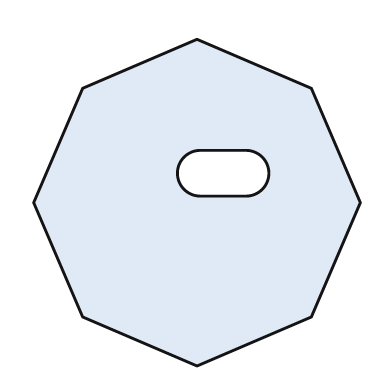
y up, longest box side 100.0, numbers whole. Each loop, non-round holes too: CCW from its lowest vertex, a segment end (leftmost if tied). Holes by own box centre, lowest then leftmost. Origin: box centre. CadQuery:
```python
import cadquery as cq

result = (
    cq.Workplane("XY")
    .moveTo(0.0, -50.0)
    .lineTo(35.0, -35.0)
    .lineTo(50.0, 0.0)
    .lineTo(35.0, 35.0)
    .lineTo(0.0, 50.0)
    .lineTo(-35.0, 35.0)
    .lineTo(-50.0, 0.0)
    .lineTo(-35.0, -35.0)
    .close()
    .moveTo(1.0, 2.0)
    .lineTo(15.0, 2.0)
    .threePointArc((22.0, 9.0), (15.0, 16.0))
    .lineTo(1.0, 16.0)
    .threePointArc((-6.0, 9.0), (1.0, 2.0))
    .close()
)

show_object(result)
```